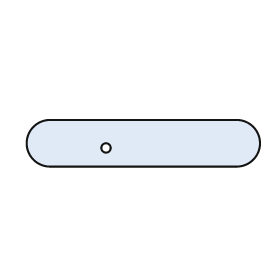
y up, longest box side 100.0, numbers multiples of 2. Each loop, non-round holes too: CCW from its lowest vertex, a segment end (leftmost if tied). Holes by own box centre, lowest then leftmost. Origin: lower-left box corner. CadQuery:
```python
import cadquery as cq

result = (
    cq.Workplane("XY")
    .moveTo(10.0, 0.0)
    .lineTo(90.0, 0.0)
    .threePointArc((100.0, 10.0), (90.0, 20.0))
    .lineTo(10.0, 20.0)
    .threePointArc((0.0, 10.0), (10.0, 0.0))
    .close()
    .moveTo(34.0, 8.0)
    .circle(2.0)
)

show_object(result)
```